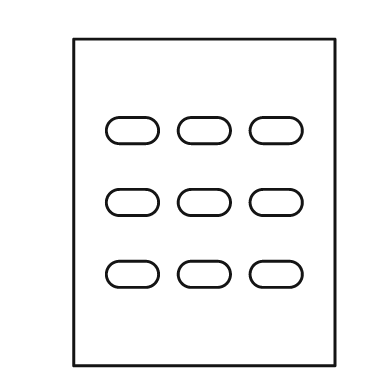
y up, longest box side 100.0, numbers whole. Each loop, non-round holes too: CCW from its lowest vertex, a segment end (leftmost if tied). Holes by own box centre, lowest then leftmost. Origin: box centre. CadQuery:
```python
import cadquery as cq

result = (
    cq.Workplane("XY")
    .moveTo(-40.0, -50.0)
    .lineTo(40.0, -50.0)
    .lineTo(40.0, 50.0)
    .lineTo(-40.0, 50.0)
    .close()
    .moveTo(-26.0, -26.0)
    .lineTo(-18.0, -26.0)
    .threePointArc((-14.0, -22.0), (-18.0, -18.0))
    .lineTo(-26.0, -18.0)
    .threePointArc((-30.0, -22.0), (-26.0, -26.0))
    .close()
    .moveTo(-4.0, -26.0)
    .lineTo(4.0, -26.0)
    .threePointArc((8.0, -22.0), (4.0, -18.0))
    .lineTo(-4.0, -18.0)
    .threePointArc((-8.0, -22.0), (-4.0, -26.0))
    .close()
    .moveTo(18.0, -26.0)
    .lineTo(26.0, -26.0)
    .threePointArc((30.0, -22.0), (26.0, -18.0))
    .lineTo(18.0, -18.0)
    .threePointArc((14.0, -22.0), (18.0, -26.0))
    .close()
    .moveTo(-26.0, -4.0)
    .lineTo(-18.0, -4.0)
    .threePointArc((-14.0, 0.0), (-18.0, 4.0))
    .lineTo(-26.0, 4.0)
    .threePointArc((-30.0, 0.0), (-26.0, -4.0))
    .close()
    .moveTo(-4.0, -4.0)
    .lineTo(4.0, -4.0)
    .threePointArc((8.0, 0.0), (4.0, 4.0))
    .lineTo(-4.0, 4.0)
    .threePointArc((-8.0, 0.0), (-4.0, -4.0))
    .close()
    .moveTo(18.0, -4.0)
    .lineTo(26.0, -4.0)
    .threePointArc((30.0, 0.0), (26.0, 4.0))
    .lineTo(18.0, 4.0)
    .threePointArc((14.0, 0.0), (18.0, -4.0))
    .close()
    .moveTo(-26.0, 18.0)
    .lineTo(-18.0, 18.0)
    .threePointArc((-14.0, 22.0), (-18.0, 26.0))
    .lineTo(-26.0, 26.0)
    .threePointArc((-30.0, 22.0), (-26.0, 18.0))
    .close()
    .moveTo(-4.0, 18.0)
    .lineTo(4.0, 18.0)
    .threePointArc((8.0, 22.0), (4.0, 26.0))
    .lineTo(-4.0, 26.0)
    .threePointArc((-8.0, 22.0), (-4.0, 18.0))
    .close()
    .moveTo(18.0, 18.0)
    .lineTo(26.0, 18.0)
    .threePointArc((30.0, 22.0), (26.0, 26.0))
    .lineTo(18.0, 26.0)
    .threePointArc((14.0, 22.0), (18.0, 18.0))
    .close()
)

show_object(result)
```